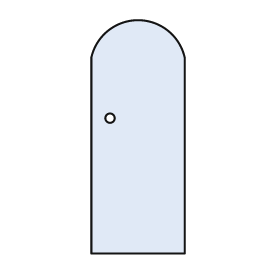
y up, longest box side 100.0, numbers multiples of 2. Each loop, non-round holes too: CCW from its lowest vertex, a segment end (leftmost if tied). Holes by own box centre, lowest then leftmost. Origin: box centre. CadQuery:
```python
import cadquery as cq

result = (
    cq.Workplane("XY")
    .moveTo(-20.0, -50.0)
    .lineTo(20.0, -50.0)
    .lineTo(20.0, 34.0)
    .threePointArc((0.0, 50.0), (-20.0, 34.0))
    .close()
    .moveTo(-12.0, 8.0)
    .circle(2.0)
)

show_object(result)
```